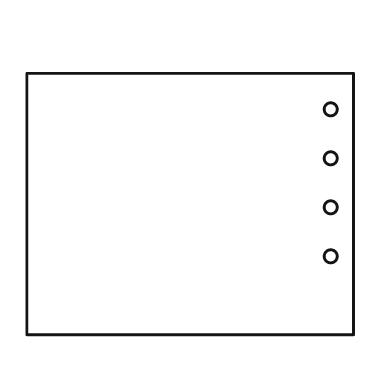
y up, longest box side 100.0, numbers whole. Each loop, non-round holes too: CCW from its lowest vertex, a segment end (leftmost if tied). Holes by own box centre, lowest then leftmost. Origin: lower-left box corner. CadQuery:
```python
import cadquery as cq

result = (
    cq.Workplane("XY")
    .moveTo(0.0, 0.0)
    .lineTo(100.0, 0.0)
    .lineTo(100.0, 80.0)
    .lineTo(0.0, 80.0)
    .close()
    .moveTo(93.0, 24.0)
    .circle(2.0)
    .moveTo(93.0, 39.0)
    .circle(2.0)
    .moveTo(93.0, 54.0)
    .circle(2.0)
    .moveTo(93.0, 69.0)
    .circle(2.0)
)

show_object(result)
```